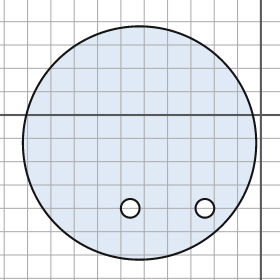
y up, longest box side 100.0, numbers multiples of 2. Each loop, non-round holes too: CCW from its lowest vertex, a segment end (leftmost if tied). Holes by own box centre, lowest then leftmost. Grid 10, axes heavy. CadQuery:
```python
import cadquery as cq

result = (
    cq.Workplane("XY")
    .moveTo(-52.0, -12.0)
    .circle(50.0)
    .moveTo(-56.0, -40.0)
    .circle(4.0)
    .moveTo(-24.0, -40.0)
    .circle(4.0)
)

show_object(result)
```